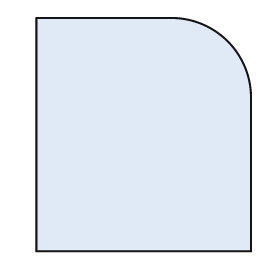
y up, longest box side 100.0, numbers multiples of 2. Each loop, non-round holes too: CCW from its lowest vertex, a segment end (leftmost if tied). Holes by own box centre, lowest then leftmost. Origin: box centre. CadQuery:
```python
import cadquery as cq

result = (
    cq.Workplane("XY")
    .moveTo(-46.0, -50.0)
    .lineTo(46.0, -50.0)
    .lineTo(46.0, 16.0)
    .threePointArc((36.0, 40.0), (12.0, 50.0))
    .lineTo(-46.0, 50.0)
    .close()
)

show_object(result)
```